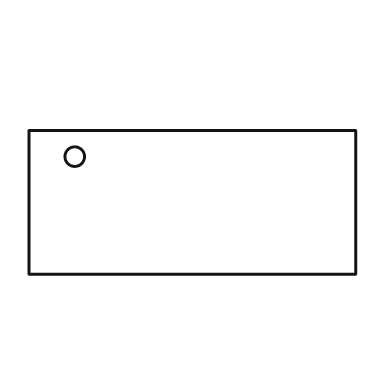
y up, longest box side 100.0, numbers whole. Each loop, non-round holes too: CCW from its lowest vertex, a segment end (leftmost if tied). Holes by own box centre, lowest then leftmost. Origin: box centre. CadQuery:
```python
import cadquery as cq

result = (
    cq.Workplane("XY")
    .moveTo(-50.0, -22.0)
    .lineTo(50.0, -22.0)
    .lineTo(50.0, 22.0)
    .lineTo(-50.0, 22.0)
    .close()
    .moveTo(-36.0, 14.0)
    .circle(3.0)
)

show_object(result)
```